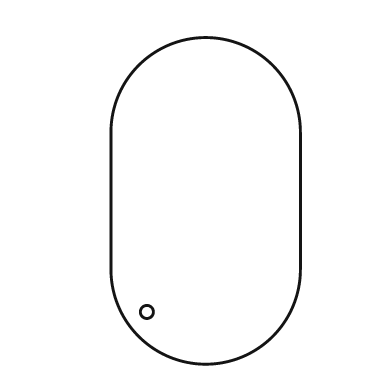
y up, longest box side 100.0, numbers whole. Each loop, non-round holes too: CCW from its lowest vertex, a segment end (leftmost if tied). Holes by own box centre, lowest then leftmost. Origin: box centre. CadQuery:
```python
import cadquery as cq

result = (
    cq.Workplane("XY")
    .moveTo(-29.0, -21.0)
    .threePointArc((0.0, -50.0), (29.0, -21.0))
    .lineTo(29.0, 21.0)
    .threePointArc((0.0, 50.0), (-29.0, 21.0))
    .close()
    .moveTo(-18.0, -34.0)
    .circle(2.0)
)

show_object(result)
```